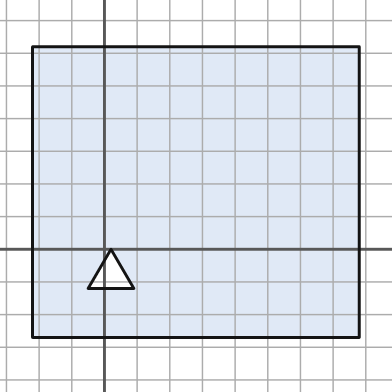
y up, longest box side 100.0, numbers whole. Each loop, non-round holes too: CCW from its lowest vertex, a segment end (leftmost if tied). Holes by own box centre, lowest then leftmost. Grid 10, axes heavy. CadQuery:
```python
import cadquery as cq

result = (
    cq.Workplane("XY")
    .moveTo(-22.0, -27.0)
    .lineTo(78.0, -27.0)
    .lineTo(78.0, 62.0)
    .lineTo(-22.0, 62.0)
    .close()
    .moveTo(-5.0, -12.0)
    .lineTo(9.0, -12.0)
    .lineTo(2.0, 0.0)
    .close()
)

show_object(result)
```